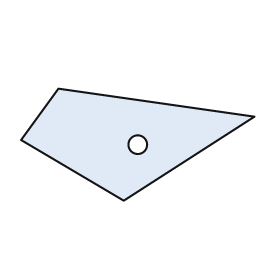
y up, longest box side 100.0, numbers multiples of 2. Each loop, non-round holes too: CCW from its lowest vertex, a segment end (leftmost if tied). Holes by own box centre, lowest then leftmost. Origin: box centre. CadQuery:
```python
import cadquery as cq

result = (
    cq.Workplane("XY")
    .moveTo(-6.0, -24.0)
    .lineTo(50.0, 12.0)
    .lineTo(-34.0, 24.0)
    .lineTo(-50.0, 2.0)
    .close()
    .moveTo(0.0, 0.0)
    .circle(4.0)
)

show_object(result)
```